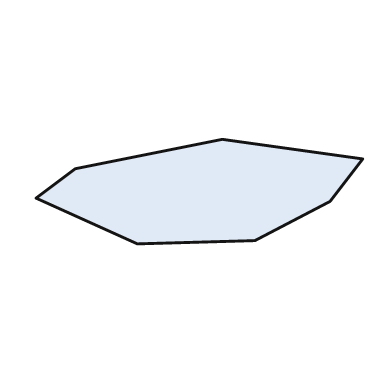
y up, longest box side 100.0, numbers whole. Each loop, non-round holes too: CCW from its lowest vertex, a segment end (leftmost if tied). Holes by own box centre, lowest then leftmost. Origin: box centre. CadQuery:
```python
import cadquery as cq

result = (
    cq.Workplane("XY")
    .moveTo(-19.0, -16.0)
    .lineTo(17.0, -15.0)
    .lineTo(40.0, -3.0)
    .lineTo(50.0, 10.0)
    .lineTo(7.0, 16.0)
    .lineTo(-38.0, 7.0)
    .lineTo(-50.0, -2.0)
    .close()
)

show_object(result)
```